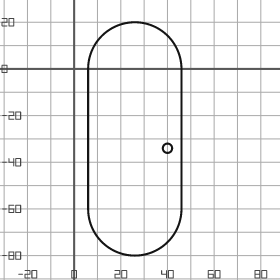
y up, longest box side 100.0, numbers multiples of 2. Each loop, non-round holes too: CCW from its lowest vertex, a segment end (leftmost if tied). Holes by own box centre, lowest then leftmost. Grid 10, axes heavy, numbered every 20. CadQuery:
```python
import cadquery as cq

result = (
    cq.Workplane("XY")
    .moveTo(6.0, -60.0)
    .threePointArc((26.0, -80.0), (46.0, -60.0))
    .lineTo(46.0, 0.0)
    .threePointArc((26.0, 20.0), (6.0, 0.0))
    .close()
    .moveTo(40.0, -34.0)
    .circle(2.0)
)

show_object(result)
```